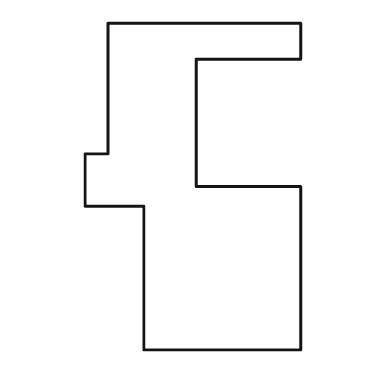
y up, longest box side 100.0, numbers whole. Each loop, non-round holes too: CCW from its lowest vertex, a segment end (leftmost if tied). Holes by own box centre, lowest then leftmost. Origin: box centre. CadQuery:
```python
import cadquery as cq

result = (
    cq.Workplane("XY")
    .moveTo(-15.0, -50.0)
    .lineTo(33.0, -50.0)
    .lineTo(33.0, 0.0)
    .lineTo(1.0, 0.0)
    .lineTo(1.0, 39.0)
    .lineTo(33.0, 39.0)
    .lineTo(33.0, 50.0)
    .lineTo(-26.0, 50.0)
    .lineTo(-26.0, 10.0)
    .lineTo(-33.0, 10.0)
    .lineTo(-33.0, -6.0)
    .lineTo(-15.0, -6.0)
    .close()
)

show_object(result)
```